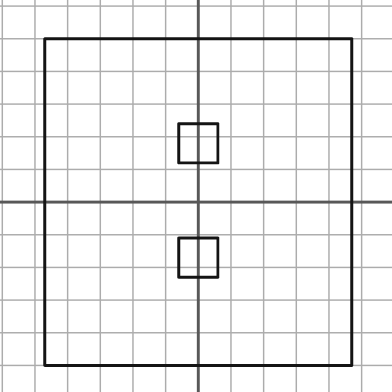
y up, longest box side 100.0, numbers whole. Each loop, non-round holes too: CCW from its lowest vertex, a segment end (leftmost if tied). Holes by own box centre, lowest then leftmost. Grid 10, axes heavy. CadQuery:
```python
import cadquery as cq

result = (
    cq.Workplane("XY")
    .moveTo(-47.0, -50.0)
    .lineTo(47.0, -50.0)
    .lineTo(47.0, 50.0)
    .lineTo(-47.0, 50.0)
    .close()
    .moveTo(-6.0, -23.0)
    .lineTo(6.0, -23.0)
    .lineTo(6.0, -11.0)
    .lineTo(-6.0, -11.0)
    .close()
    .moveTo(-6.0, 12.0)
    .lineTo(6.0, 12.0)
    .lineTo(6.0, 24.0)
    .lineTo(-6.0, 24.0)
    .close()
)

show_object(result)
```